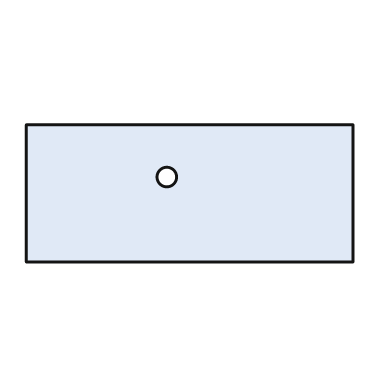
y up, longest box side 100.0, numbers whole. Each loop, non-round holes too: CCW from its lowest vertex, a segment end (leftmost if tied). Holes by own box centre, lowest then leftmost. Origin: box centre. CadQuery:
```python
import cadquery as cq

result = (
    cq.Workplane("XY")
    .moveTo(-50.0, -21.0)
    .lineTo(50.0, -21.0)
    .lineTo(50.0, 21.0)
    .lineTo(-50.0, 21.0)
    .close()
    .moveTo(-7.0, 5.0)
    .circle(3.0)
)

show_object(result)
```